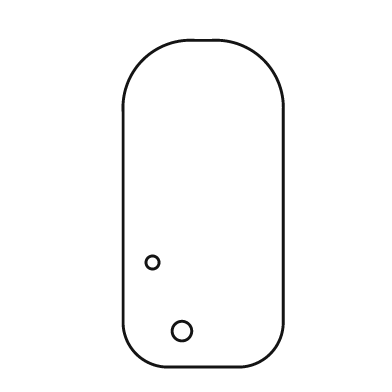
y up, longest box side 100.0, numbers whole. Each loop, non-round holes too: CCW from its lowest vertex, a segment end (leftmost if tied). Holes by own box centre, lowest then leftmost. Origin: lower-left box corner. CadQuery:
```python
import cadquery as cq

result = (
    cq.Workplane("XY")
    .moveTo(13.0, 0.0)
    .lineTo(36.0, 0.0)
    .threePointArc((45.0, 4.0), (49.0, 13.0))
    .lineTo(49.0, 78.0)
    .threePointArc((43.0, 94.0), (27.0, 100.0))
    .lineTo(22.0, 100.0)
    .threePointArc((6.0, 94.0), (0.0, 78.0))
    .lineTo(0.0, 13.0)
    .threePointArc((4.0, 4.0), (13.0, 0.0))
    .close()
    .moveTo(18.0, 11.0)
    .circle(3.0)
    .moveTo(9.0, 32.0)
    .circle(2.0)
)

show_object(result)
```